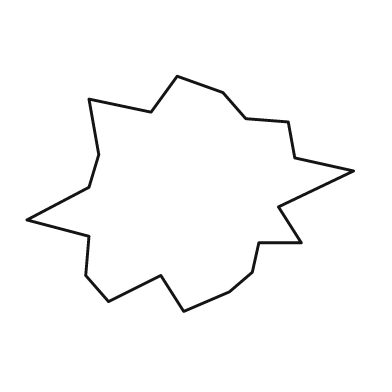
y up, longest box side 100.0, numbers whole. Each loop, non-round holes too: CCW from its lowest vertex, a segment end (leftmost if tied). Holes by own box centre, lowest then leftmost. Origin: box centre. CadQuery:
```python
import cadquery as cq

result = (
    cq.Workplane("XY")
    .moveTo(-2.0, -36.0)
    .lineTo(12.0, -30.0)
    .lineTo(19.0, -24.0)
    .lineTo(21.0, -15.0)
    .lineTo(34.0, -15.0)
    .lineTo(27.0, -4.0)
    .lineTo(50.0, 7.0)
    .lineTo(32.0, 11.0)
    .lineTo(30.0, 22.0)
    .lineTo(17.0, 23.0)
    .lineTo(10.0, 31.0)
    .lineTo(-4.0, 36.0)
    .lineTo(-12.0, 25.0)
    .lineTo(-31.0, 29.0)
    .lineTo(-28.0, 12.0)
    .lineTo(-31.0, 2.0)
    .lineTo(-50.0, -8.0)
    .lineTo(-31.0, -13.0)
    .lineTo(-32.0, -25.0)
    .lineTo(-25.0, -33.0)
    .lineTo(-9.0, -25.0)
    .close()
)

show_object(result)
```